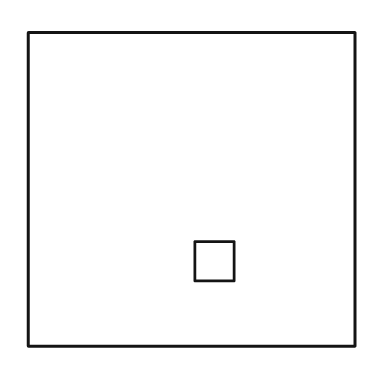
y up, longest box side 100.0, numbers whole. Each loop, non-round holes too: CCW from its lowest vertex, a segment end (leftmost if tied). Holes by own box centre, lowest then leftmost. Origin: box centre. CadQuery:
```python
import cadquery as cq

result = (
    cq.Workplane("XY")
    .moveTo(-50.0, -48.0)
    .lineTo(50.0, -48.0)
    .lineTo(50.0, 48.0)
    .lineTo(-50.0, 48.0)
    .close()
    .moveTo(1.0, -28.0)
    .lineTo(13.0, -28.0)
    .lineTo(13.0, -16.0)
    .lineTo(1.0, -16.0)
    .close()
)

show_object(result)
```